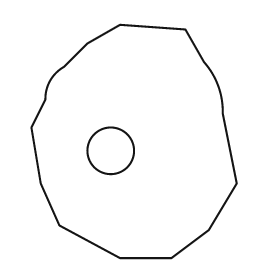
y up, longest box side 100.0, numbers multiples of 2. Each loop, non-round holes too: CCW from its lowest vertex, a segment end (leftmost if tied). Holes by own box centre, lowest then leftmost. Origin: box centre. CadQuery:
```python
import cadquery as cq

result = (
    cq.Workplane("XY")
    .moveTo(-6.0, -50.0)
    .lineTo(16.0, -50.0)
    .lineTo(32.0, -38.0)
    .lineTo(44.0, -18.0)
    .lineTo(38.0, 12.0)
    .threePointArc((36.0, 24.0), (30.0, 34.0))
    .lineTo(22.0, 48.0)
    .lineTo(-6.0, 50.0)
    .lineTo(-20.0, 42.0)
    .lineTo(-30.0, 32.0)
    .threePointArc((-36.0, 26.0), (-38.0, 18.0))
    .lineTo(-44.0, 6.0)
    .lineTo(-40.0, -18.0)
    .lineTo(-32.0, -36.0)
    .close()
    .moveTo(-10.0, -4.0)
    .circle(10.0)
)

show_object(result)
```